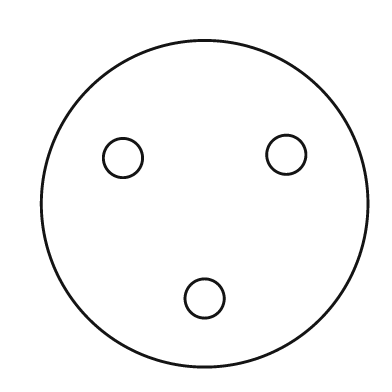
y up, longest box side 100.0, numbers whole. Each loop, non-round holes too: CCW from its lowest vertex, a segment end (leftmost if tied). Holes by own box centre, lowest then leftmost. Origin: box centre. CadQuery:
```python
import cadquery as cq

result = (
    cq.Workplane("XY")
    .moveTo(0.0, 0.0)
    .circle(50.0)
    .moveTo(0.0, -29.0)
    .circle(6.0)
    .moveTo(-25.0, 14.0)
    .circle(6.0)
    .moveTo(25.0, 15.0)
    .circle(6.0)
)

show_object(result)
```